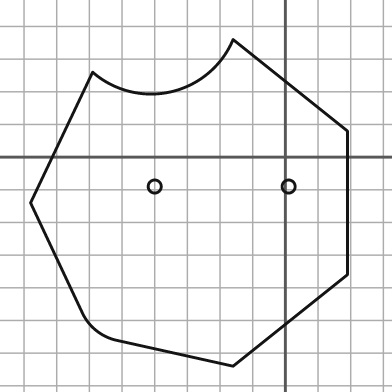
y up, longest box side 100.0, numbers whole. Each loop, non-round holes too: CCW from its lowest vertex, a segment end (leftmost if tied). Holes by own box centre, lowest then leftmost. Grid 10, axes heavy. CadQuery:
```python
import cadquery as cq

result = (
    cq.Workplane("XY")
    .moveTo(-16.0, -64.0)
    .lineTo(19.0, -36.0)
    .lineTo(19.0, 8.0)
    .lineTo(-16.0, 36.0)
    .threePointArc((-35.0, 20.0), (-59.0, 26.0))
    .lineTo(-78.0, -14.0)
    .lineTo(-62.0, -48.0)
    .threePointArc((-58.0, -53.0), (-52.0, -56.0))
    .close()
    .moveTo(-40.0, -9.0)
    .circle(2.0)
    .moveTo(1.0, -9.0)
    .circle(2.0)
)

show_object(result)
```